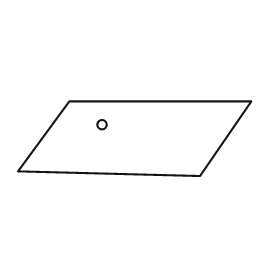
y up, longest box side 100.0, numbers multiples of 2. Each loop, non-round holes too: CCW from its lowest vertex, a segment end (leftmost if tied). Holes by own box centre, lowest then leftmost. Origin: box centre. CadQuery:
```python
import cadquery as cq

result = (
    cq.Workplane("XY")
    .moveTo(28.0, -16.0)
    .lineTo(50.0, 16.0)
    .lineTo(-28.0, 16.0)
    .lineTo(-50.0, -14.0)
    .close()
    .moveTo(-14.0, 6.0)
    .circle(2.0)
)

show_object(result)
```